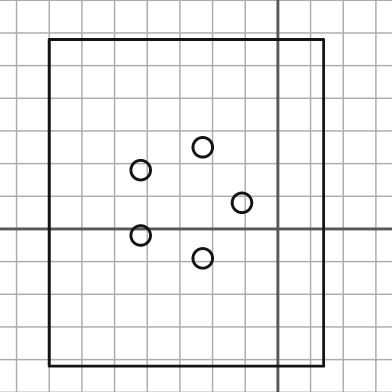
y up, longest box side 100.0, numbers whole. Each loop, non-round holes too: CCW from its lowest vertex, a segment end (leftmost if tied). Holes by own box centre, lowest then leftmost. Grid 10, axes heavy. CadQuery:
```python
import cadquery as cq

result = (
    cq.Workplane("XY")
    .moveTo(-70.0, -42.0)
    .lineTo(14.0, -42.0)
    .lineTo(14.0, 58.0)
    .lineTo(-70.0, 58.0)
    .close()
    .moveTo(-23.0, -9.0)
    .circle(3.0)
    .moveTo(-42.0, -2.0)
    .circle(3.0)
    .moveTo(-11.0, 8.0)
    .circle(3.0)
    .moveTo(-42.0, 18.0)
    .circle(3.0)
    .moveTo(-23.0, 25.0)
    .circle(3.0)
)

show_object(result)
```